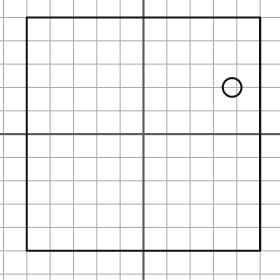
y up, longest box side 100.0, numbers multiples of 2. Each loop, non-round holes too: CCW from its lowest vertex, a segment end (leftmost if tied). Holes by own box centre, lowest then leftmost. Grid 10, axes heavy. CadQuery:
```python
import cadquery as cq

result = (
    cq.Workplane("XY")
    .moveTo(-50.0, -50.0)
    .lineTo(50.0, -50.0)
    .lineTo(50.0, 50.0)
    .lineTo(-50.0, 50.0)
    .close()
    .moveTo(38.0, 20.0)
    .circle(4.0)
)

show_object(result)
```